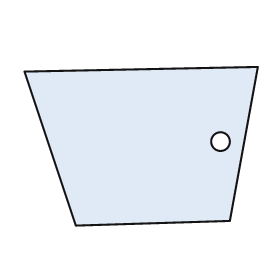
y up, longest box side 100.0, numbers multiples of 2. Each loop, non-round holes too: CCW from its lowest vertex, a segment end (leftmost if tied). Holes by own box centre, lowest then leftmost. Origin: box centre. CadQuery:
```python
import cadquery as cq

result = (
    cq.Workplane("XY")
    .moveTo(-28.0, -34.0)
    .lineTo(38.0, -32.0)
    .lineTo(50.0, 34.0)
    .lineTo(-50.0, 32.0)
    .close()
    .moveTo(34.0, 2.0)
    .circle(4.0)
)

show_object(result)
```